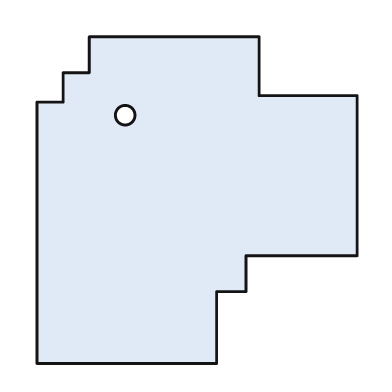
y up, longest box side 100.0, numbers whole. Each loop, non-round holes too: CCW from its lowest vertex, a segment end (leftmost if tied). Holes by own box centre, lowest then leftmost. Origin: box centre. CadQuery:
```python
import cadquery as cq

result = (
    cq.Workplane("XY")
    .moveTo(-49.0, -50.0)
    .lineTo(6.0, -50.0)
    .lineTo(6.0, -28.0)
    .lineTo(15.0, -28.0)
    .lineTo(15.0, -17.0)
    .lineTo(49.0, -17.0)
    .lineTo(49.0, 32.0)
    .lineTo(19.0, 32.0)
    .lineTo(19.0, 50.0)
    .lineTo(-33.0, 50.0)
    .lineTo(-33.0, 39.0)
    .lineTo(-41.0, 39.0)
    .lineTo(-41.0, 30.0)
    .lineTo(-49.0, 30.0)
    .close()
    .moveTo(-22.0, 26.0)
    .circle(3.0)
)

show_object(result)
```